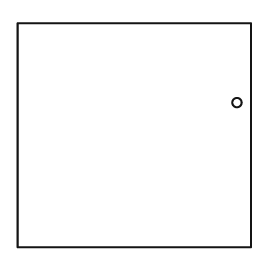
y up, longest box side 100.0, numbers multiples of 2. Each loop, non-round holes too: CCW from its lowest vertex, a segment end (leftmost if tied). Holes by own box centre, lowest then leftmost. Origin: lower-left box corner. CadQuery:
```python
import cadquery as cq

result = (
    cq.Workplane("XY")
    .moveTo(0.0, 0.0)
    .lineTo(100.0, 0.0)
    .lineTo(100.0, 96.0)
    .lineTo(0.0, 96.0)
    .close()
    .moveTo(94.0, 62.0)
    .circle(2.0)
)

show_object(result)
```